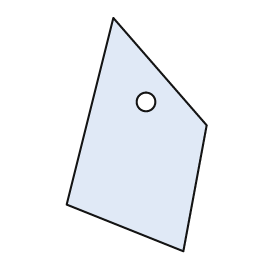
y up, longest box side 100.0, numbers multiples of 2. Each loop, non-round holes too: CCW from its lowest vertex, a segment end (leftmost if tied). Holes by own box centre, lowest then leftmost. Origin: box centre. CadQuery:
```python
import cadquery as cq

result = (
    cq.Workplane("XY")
    .moveTo(20.0, -50.0)
    .lineTo(30.0, 4.0)
    .lineTo(-10.0, 50.0)
    .lineTo(-30.0, -30.0)
    .close()
    .moveTo(4.0, 14.0)
    .circle(4.0)
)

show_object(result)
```